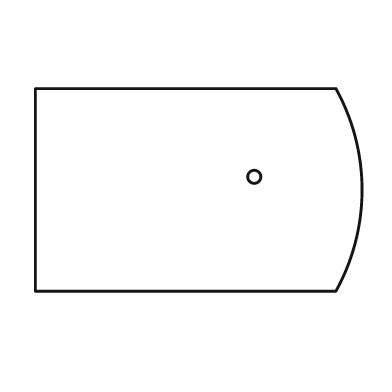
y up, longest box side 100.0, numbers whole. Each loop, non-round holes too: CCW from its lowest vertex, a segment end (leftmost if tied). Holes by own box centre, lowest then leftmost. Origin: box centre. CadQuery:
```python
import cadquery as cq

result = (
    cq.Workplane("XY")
    .moveTo(-50.0, -31.0)
    .lineTo(42.0, -31.0)
    .threePointArc((50.0, 0.0), (42.0, 31.0))
    .lineTo(-50.0, 31.0)
    .close()
    .moveTo(17.0, 4.0)
    .circle(2.0)
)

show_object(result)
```